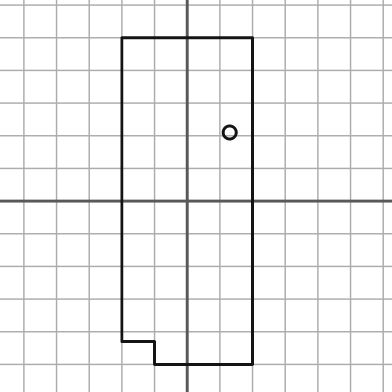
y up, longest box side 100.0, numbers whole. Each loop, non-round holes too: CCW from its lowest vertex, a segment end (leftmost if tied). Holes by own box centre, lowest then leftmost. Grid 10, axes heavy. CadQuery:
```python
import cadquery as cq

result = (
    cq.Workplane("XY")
    .moveTo(-10.0, -50.0)
    .lineTo(20.0, -50.0)
    .lineTo(20.0, 50.0)
    .lineTo(-20.0, 50.0)
    .lineTo(-20.0, -43.0)
    .lineTo(-10.0, -43.0)
    .close()
    .moveTo(13.0, 21.0)
    .circle(2.0)
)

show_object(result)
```